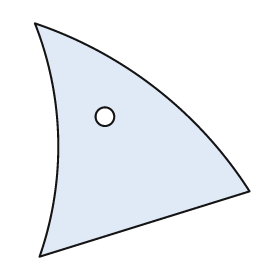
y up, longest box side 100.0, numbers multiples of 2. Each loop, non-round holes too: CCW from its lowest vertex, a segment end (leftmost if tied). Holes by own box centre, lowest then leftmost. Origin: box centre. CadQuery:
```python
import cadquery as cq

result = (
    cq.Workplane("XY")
    .moveTo(-44.0, -50.0)
    .lineTo(46.0, -22.0)
    .threePointArc((6.0, 22.0), (-46.0, 50.0))
    .threePointArc((-36.0, 0.0), (-44.0, -50.0))
    .close()
    .moveTo(-16.0, 10.0)
    .circle(4.0)
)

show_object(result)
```